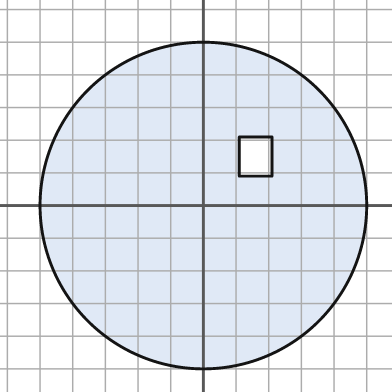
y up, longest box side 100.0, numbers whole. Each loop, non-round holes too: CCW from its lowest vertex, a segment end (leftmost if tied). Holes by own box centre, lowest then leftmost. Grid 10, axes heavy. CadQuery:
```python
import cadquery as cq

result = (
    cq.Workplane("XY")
    .moveTo(0.0, 0.0)
    .circle(50.0)
    .moveTo(11.0, 9.0)
    .lineTo(21.0, 9.0)
    .lineTo(21.0, 21.0)
    .lineTo(11.0, 21.0)
    .close()
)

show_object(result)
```